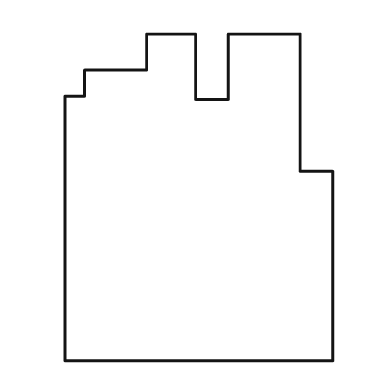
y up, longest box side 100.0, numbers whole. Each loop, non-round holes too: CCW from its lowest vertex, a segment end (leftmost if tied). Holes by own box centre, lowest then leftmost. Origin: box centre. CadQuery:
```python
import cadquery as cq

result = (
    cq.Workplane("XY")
    .moveTo(-41.0, -50.0)
    .lineTo(41.0, -50.0)
    .lineTo(41.0, 8.0)
    .lineTo(31.0, 8.0)
    .lineTo(31.0, 50.0)
    .lineTo(9.0, 50.0)
    .lineTo(9.0, 30.0)
    .lineTo(-1.0, 30.0)
    .lineTo(-1.0, 50.0)
    .lineTo(-16.0, 50.0)
    .lineTo(-16.0, 39.0)
    .lineTo(-35.0, 39.0)
    .lineTo(-35.0, 31.0)
    .lineTo(-41.0, 31.0)
    .close()
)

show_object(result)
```